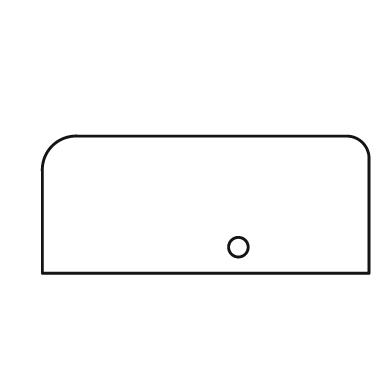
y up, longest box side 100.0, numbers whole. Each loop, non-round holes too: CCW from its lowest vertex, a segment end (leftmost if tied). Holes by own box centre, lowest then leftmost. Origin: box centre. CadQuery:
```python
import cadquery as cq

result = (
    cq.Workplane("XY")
    .moveTo(-50.0, -21.0)
    .lineTo(50.0, -21.0)
    .lineTo(50.0, 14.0)
    .threePointArc((48.0, 19.0), (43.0, 21.0))
    .lineTo(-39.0, 21.0)
    .threePointArc((-47.0, 18.0), (-50.0, 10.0))
    .close()
    .moveTo(10.0, -13.0)
    .circle(3.0)
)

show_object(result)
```